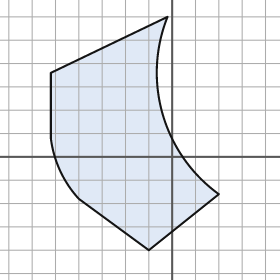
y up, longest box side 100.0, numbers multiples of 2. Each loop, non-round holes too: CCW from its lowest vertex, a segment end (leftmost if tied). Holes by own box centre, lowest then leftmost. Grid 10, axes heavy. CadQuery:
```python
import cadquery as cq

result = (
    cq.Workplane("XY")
    .moveTo(-10.0, -40.0)
    .lineTo(20.0, -16.0)
    .threePointArc((-4.0, 18.0), (-2.0, 60.0))
    .lineTo(-52.0, 36.0)
    .lineTo(-52.0, 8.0)
    .threePointArc((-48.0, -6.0), (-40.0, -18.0))
    .close()
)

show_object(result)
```